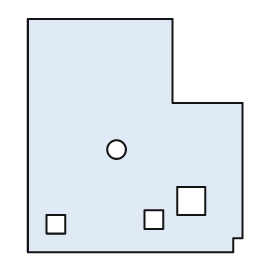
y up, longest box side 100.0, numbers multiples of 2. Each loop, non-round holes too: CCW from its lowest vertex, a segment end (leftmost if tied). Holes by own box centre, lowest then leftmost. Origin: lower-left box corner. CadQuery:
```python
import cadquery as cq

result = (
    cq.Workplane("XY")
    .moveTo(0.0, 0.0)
    .lineTo(88.0, 0.0)
    .lineTo(88.0, 6.0)
    .lineTo(92.0, 6.0)
    .lineTo(92.0, 64.0)
    .lineTo(62.0, 64.0)
    .lineTo(62.0, 100.0)
    .lineTo(0.0, 100.0)
    .close()
    .moveTo(8.0, 8.0)
    .lineTo(16.0, 8.0)
    .lineTo(16.0, 16.0)
    .lineTo(8.0, 16.0)
    .close()
    .moveTo(50.0, 10.0)
    .lineTo(58.0, 10.0)
    .lineTo(58.0, 18.0)
    .lineTo(50.0, 18.0)
    .close()
    .moveTo(64.0, 16.0)
    .lineTo(76.0, 16.0)
    .lineTo(76.0, 28.0)
    .lineTo(64.0, 28.0)
    .close()
    .moveTo(38.0, 44.0)
    .circle(4.0)
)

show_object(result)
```